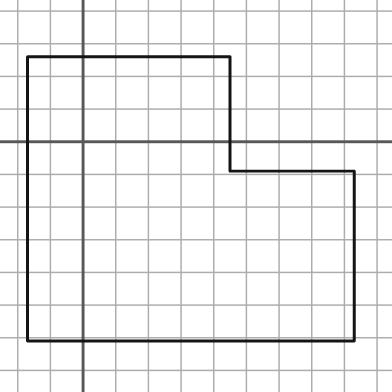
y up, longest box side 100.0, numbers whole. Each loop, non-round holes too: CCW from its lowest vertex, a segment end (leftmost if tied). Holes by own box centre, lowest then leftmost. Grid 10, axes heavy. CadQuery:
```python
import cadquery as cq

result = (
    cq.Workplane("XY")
    .moveTo(-17.0, -61.0)
    .lineTo(83.0, -61.0)
    .lineTo(83.0, -9.0)
    .lineTo(45.0, -9.0)
    .lineTo(45.0, 26.0)
    .lineTo(-17.0, 26.0)
    .close()
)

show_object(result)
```